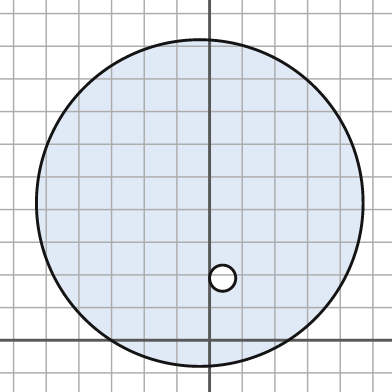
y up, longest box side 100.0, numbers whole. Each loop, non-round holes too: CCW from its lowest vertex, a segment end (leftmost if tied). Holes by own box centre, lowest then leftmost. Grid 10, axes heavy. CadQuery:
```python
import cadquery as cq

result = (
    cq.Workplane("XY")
    .moveTo(-3.0, 42.0)
    .circle(50.0)
    .moveTo(4.0, 19.0)
    .circle(4.0)
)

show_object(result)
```